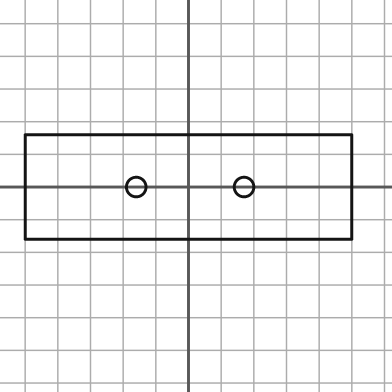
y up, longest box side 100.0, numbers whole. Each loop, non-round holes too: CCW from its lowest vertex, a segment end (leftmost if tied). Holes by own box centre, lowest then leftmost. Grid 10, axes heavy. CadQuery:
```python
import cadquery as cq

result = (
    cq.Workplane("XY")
    .moveTo(-50.0, -16.0)
    .lineTo(50.0, -16.0)
    .lineTo(50.0, 16.0)
    .lineTo(-50.0, 16.0)
    .close()
    .moveTo(-16.0, 0.0)
    .circle(3.0)
    .moveTo(17.0, 0.0)
    .circle(3.0)
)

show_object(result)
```